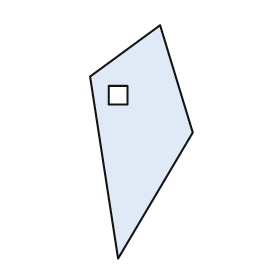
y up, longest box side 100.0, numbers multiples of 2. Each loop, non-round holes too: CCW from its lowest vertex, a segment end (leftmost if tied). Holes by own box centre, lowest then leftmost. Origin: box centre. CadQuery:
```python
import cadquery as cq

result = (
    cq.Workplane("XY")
    .moveTo(-10.0, -50.0)
    .lineTo(22.0, 4.0)
    .lineTo(8.0, 50.0)
    .lineTo(-22.0, 28.0)
    .close()
    .moveTo(-14.0, 16.0)
    .lineTo(-6.0, 16.0)
    .lineTo(-6.0, 24.0)
    .lineTo(-14.0, 24.0)
    .close()
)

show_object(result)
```